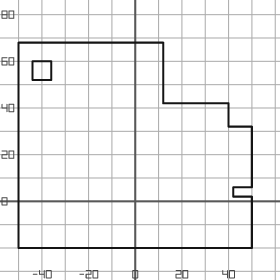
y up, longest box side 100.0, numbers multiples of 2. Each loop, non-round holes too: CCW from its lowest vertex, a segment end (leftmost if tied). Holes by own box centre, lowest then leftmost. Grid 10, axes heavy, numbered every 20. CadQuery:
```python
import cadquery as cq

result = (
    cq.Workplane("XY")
    .moveTo(-50.0, -20.0)
    .lineTo(50.0, -20.0)
    .lineTo(50.0, 2.0)
    .lineTo(42.0, 2.0)
    .lineTo(42.0, 6.0)
    .lineTo(50.0, 6.0)
    .lineTo(50.0, 32.0)
    .lineTo(40.0, 32.0)
    .lineTo(40.0, 42.0)
    .lineTo(12.0, 42.0)
    .lineTo(12.0, 68.0)
    .lineTo(-50.0, 68.0)
    .close()
    .moveTo(-44.0, 52.0)
    .lineTo(-36.0, 52.0)
    .lineTo(-36.0, 60.0)
    .lineTo(-44.0, 60.0)
    .close()
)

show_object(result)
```